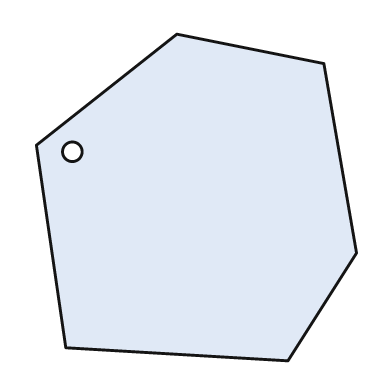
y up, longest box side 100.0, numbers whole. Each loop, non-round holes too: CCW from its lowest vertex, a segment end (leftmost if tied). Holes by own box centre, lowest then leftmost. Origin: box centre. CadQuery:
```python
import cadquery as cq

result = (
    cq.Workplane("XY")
    .moveTo(28.0, -50.0)
    .lineTo(49.0, -17.0)
    .lineTo(39.0, 41.0)
    .lineTo(-6.0, 50.0)
    .lineTo(-49.0, 16.0)
    .lineTo(-40.0, -46.0)
    .close()
    .moveTo(-38.0, 14.0)
    .circle(3.0)
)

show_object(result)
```